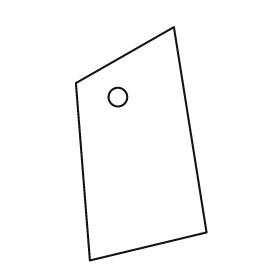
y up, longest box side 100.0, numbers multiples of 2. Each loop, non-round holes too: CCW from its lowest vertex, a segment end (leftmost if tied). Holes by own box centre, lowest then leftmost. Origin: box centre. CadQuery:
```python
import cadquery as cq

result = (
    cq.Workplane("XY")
    .moveTo(-22.0, -50.0)
    .lineTo(28.0, -38.0)
    .lineTo(14.0, 50.0)
    .lineTo(-28.0, 26.0)
    .close()
    .moveTo(-10.0, 20.0)
    .circle(4.0)
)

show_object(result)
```